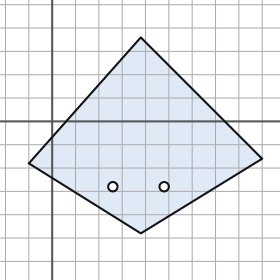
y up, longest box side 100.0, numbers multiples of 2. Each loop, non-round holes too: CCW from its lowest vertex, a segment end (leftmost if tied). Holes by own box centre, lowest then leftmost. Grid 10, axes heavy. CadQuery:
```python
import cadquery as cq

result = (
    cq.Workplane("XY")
    .moveTo(38.0, -48.0)
    .lineTo(90.0, -16.0)
    .lineTo(38.0, 36.0)
    .lineTo(-10.0, -18.0)
    .close()
    .moveTo(26.0, -28.0)
    .circle(2.0)
    .moveTo(48.0, -28.0)
    .circle(2.0)
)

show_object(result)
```